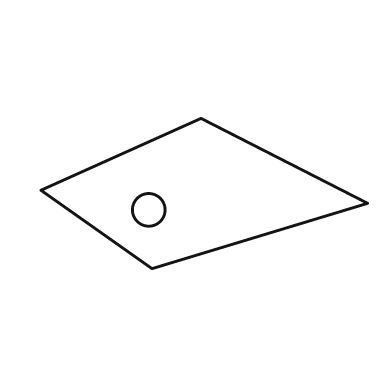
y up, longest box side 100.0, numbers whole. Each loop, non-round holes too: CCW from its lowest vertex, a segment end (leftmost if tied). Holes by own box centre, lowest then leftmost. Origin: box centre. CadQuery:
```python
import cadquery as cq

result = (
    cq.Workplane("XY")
    .moveTo(-16.0, -23.0)
    .lineTo(50.0, -3.0)
    .lineTo(-1.0, 23.0)
    .lineTo(-50.0, 1.0)
    .close()
    .moveTo(-17.0, -5.0)
    .circle(5.0)
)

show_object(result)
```